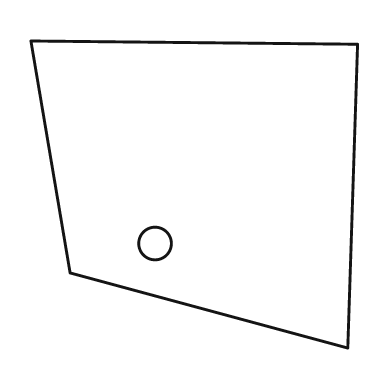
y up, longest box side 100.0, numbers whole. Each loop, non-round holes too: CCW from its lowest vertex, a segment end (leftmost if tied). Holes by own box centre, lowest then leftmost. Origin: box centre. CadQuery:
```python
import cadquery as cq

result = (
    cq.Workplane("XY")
    .moveTo(47.0, -47.0)
    .lineTo(50.0, 46.0)
    .lineTo(-50.0, 47.0)
    .lineTo(-38.0, -24.0)
    .close()
    .moveTo(-12.0, -15.0)
    .circle(5.0)
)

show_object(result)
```